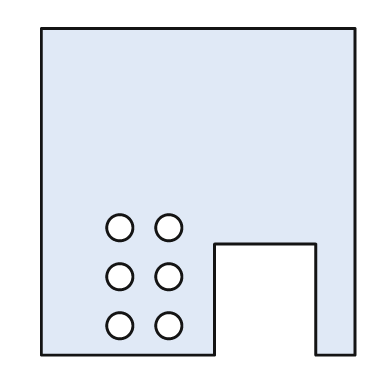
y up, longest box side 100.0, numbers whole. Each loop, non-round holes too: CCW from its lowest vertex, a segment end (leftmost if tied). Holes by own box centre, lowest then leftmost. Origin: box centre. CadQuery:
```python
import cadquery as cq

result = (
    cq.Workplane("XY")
    .moveTo(-48.0, -50.0)
    .lineTo(5.0, -50.0)
    .lineTo(5.0, -16.0)
    .lineTo(36.0, -16.0)
    .lineTo(36.0, -50.0)
    .lineTo(48.0, -50.0)
    .lineTo(48.0, 50.0)
    .lineTo(-48.0, 50.0)
    .close()
    .moveTo(-24.0, -41.0)
    .circle(4.0)
    .moveTo(-9.0, -41.0)
    .circle(4.0)
    .moveTo(-24.0, -26.0)
    .circle(4.0)
    .moveTo(-9.0, -26.0)
    .circle(4.0)
    .moveTo(-24.0, -11.0)
    .circle(4.0)
    .moveTo(-9.0, -11.0)
    .circle(4.0)
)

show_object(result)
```